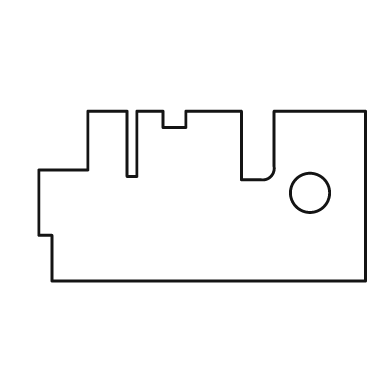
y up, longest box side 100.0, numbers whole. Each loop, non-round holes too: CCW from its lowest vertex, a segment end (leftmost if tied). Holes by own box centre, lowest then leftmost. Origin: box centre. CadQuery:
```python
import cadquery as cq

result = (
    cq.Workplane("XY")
    .moveTo(-46.0, -26.0)
    .lineTo(50.0, -26.0)
    .lineTo(50.0, 26.0)
    .lineTo(22.0, 26.0)
    .lineTo(22.0, 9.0)
    .threePointArc((21.0, 6.0), (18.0, 5.0))
    .lineTo(12.0, 5.0)
    .lineTo(12.0, 26.0)
    .lineTo(-5.0, 26.0)
    .lineTo(-5.0, 21.0)
    .lineTo(-12.0, 21.0)
    .lineTo(-12.0, 26.0)
    .lineTo(-20.0, 26.0)
    .lineTo(-20.0, 6.0)
    .lineTo(-23.0, 6.0)
    .lineTo(-23.0, 26.0)
    .lineTo(-35.0, 26.0)
    .lineTo(-35.0, 8.0)
    .lineTo(-50.0, 8.0)
    .lineTo(-50.0, -12.0)
    .lineTo(-46.0, -12.0)
    .close()
    .moveTo(33.0, 1.0)
    .circle(6.0)
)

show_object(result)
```